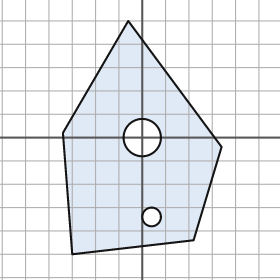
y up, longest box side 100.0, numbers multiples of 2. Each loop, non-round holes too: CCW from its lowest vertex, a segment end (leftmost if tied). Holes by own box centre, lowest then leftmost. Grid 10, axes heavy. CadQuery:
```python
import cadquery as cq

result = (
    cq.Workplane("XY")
    .moveTo(-30.0, -50.0)
    .lineTo(22.0, -44.0)
    .lineTo(34.0, -4.0)
    .lineTo(-6.0, 50.0)
    .lineTo(-34.0, 2.0)
    .close()
    .moveTo(4.0, -34.0)
    .circle(4.0)
    .moveTo(0.0, 0.0)
    .circle(8.0)
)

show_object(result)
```